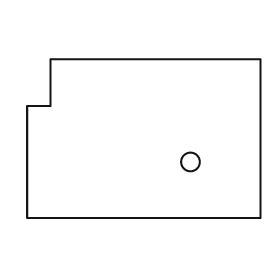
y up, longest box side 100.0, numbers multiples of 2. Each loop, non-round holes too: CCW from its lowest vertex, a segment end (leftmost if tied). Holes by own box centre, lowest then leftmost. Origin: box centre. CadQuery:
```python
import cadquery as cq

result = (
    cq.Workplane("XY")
    .moveTo(-50.0, -34.0)
    .lineTo(50.0, -34.0)
    .lineTo(50.0, 34.0)
    .lineTo(-40.0, 34.0)
    .lineTo(-40.0, 14.0)
    .lineTo(-50.0, 14.0)
    .close()
    .moveTo(20.0, -10.0)
    .circle(4.0)
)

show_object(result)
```